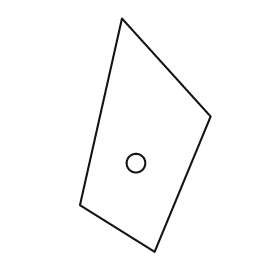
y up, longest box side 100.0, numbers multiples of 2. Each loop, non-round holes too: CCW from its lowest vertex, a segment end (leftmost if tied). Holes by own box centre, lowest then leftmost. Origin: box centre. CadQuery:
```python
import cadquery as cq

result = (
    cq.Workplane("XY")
    .moveTo(4.0, -50.0)
    .lineTo(28.0, 8.0)
    .lineTo(-10.0, 50.0)
    .lineTo(-28.0, -30.0)
    .close()
    .moveTo(-4.0, -12.0)
    .circle(4.0)
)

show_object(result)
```